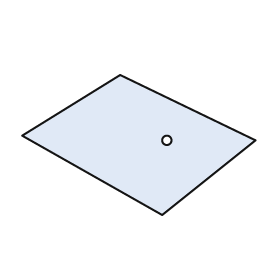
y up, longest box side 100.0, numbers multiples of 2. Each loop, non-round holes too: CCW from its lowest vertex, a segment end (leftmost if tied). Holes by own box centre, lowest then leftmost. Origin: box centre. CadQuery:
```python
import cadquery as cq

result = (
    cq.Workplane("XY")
    .moveTo(10.0, -30.0)
    .lineTo(50.0, 2.0)
    .lineTo(-8.0, 30.0)
    .lineTo(-50.0, 4.0)
    .close()
    .moveTo(12.0, 2.0)
    .circle(2.0)
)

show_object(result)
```